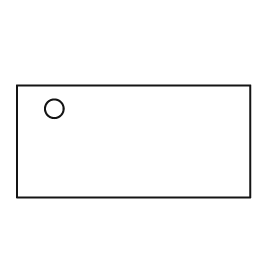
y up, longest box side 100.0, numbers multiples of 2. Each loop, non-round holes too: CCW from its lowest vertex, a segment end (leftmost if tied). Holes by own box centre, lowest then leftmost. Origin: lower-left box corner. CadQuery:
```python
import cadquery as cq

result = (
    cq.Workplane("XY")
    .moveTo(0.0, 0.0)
    .lineTo(100.0, 0.0)
    .lineTo(100.0, 48.0)
    .lineTo(0.0, 48.0)
    .close()
    .moveTo(16.0, 38.0)
    .circle(4.0)
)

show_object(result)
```